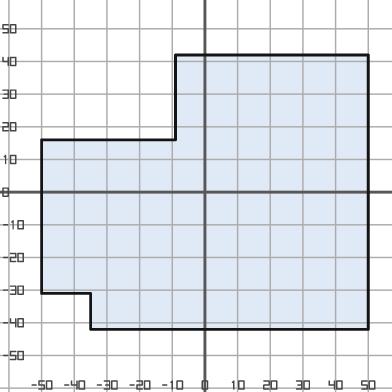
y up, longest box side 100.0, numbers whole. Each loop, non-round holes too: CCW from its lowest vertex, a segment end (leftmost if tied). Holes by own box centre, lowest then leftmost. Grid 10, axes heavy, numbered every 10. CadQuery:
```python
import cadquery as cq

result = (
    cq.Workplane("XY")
    .moveTo(-35.0, -42.0)
    .lineTo(50.0, -42.0)
    .lineTo(50.0, 42.0)
    .lineTo(-9.0, 42.0)
    .lineTo(-9.0, 16.0)
    .lineTo(-50.0, 16.0)
    .lineTo(-50.0, -31.0)
    .lineTo(-35.0, -31.0)
    .close()
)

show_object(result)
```